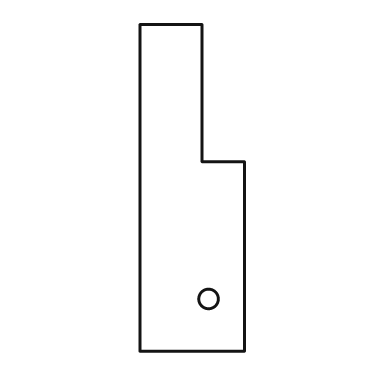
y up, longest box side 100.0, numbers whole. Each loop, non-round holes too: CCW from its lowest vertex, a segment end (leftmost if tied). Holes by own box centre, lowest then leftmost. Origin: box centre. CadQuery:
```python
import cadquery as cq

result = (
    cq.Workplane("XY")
    .moveTo(-16.0, -50.0)
    .lineTo(16.0, -50.0)
    .lineTo(16.0, 8.0)
    .lineTo(3.0, 8.0)
    .lineTo(3.0, 50.0)
    .lineTo(-16.0, 50.0)
    .close()
    .moveTo(5.0, -34.0)
    .circle(3.0)
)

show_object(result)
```